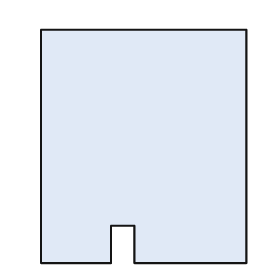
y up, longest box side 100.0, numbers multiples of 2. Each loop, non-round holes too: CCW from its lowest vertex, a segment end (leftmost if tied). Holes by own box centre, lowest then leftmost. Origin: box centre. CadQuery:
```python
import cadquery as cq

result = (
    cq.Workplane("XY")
    .moveTo(-44.0, -50.0)
    .lineTo(-14.0, -50.0)
    .lineTo(-14.0, -34.0)
    .lineTo(-4.0, -34.0)
    .lineTo(-4.0, -50.0)
    .lineTo(44.0, -50.0)
    .lineTo(44.0, 50.0)
    .lineTo(-44.0, 50.0)
    .close()
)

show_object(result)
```